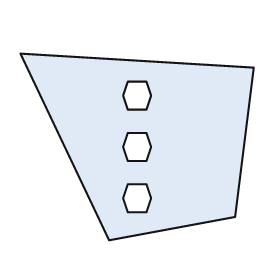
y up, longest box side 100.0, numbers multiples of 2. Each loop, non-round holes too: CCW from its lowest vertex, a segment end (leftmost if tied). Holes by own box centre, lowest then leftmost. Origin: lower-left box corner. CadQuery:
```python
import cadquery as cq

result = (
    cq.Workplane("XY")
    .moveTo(38.0, 0.0)
    .lineTo(92.0, 10.0)
    .lineTo(100.0, 74.0)
    .lineTo(0.0, 80.0)
    .close()
    .moveTo(46.0, 12.0)
    .lineTo(54.0, 12.0)
    .lineTo(56.0, 18.0)
    .lineTo(54.0, 24.0)
    .lineTo(46.0, 24.0)
    .lineTo(44.0, 18.0)
    .close()
    .moveTo(46.0, 34.0)
    .lineTo(54.0, 34.0)
    .lineTo(56.0, 40.0)
    .lineTo(54.0, 46.0)
    .lineTo(46.0, 46.0)
    .lineTo(44.0, 40.0)
    .close()
    .moveTo(46.0, 56.0)
    .lineTo(54.0, 56.0)
    .lineTo(56.0, 62.0)
    .lineTo(54.0, 68.0)
    .lineTo(46.0, 68.0)
    .lineTo(44.0, 62.0)
    .close()
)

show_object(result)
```